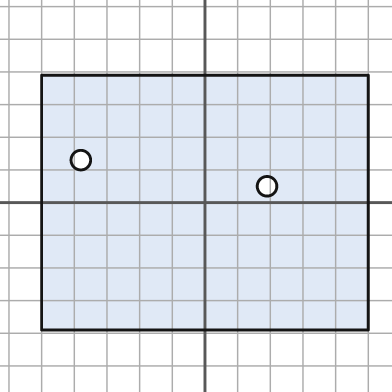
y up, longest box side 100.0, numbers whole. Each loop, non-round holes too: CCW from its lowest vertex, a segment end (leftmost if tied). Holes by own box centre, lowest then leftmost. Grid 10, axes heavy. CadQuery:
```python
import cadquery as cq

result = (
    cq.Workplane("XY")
    .moveTo(-50.0, -39.0)
    .lineTo(50.0, -39.0)
    .lineTo(50.0, 39.0)
    .lineTo(-50.0, 39.0)
    .close()
    .moveTo(19.0, 5.0)
    .circle(3.0)
    .moveTo(-38.0, 13.0)
    .circle(3.0)
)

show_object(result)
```